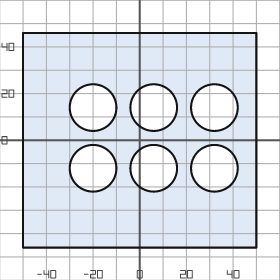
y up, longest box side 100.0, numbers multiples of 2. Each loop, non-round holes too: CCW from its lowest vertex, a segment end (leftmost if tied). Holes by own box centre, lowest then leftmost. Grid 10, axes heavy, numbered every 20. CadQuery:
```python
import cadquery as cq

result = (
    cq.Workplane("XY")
    .moveTo(-50.0, -46.0)
    .lineTo(50.0, -46.0)
    .lineTo(50.0, 46.0)
    .lineTo(-50.0, 46.0)
    .close()
    .moveTo(-20.0, -12.0)
    .circle(10.0)
    .moveTo(6.0, -12.0)
    .circle(10.0)
    .moveTo(32.0, -12.0)
    .circle(10.0)
    .moveTo(-20.0, 14.0)
    .circle(10.0)
    .moveTo(6.0, 14.0)
    .circle(10.0)
    .moveTo(32.0, 14.0)
    .circle(10.0)
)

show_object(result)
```